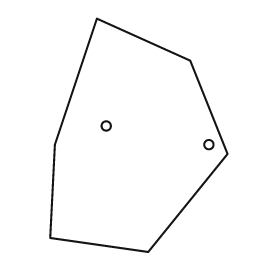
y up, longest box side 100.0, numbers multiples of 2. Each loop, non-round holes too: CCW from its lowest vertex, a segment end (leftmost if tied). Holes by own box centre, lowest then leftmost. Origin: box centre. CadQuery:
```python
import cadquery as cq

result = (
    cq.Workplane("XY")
    .moveTo(4.0, -50.0)
    .lineTo(38.0, -8.0)
    .lineTo(22.0, 32.0)
    .lineTo(-18.0, 50.0)
    .lineTo(-36.0, -4.0)
    .lineTo(-38.0, -44.0)
    .close()
    .moveTo(30.0, -4.0)
    .circle(2.0)
    .moveTo(-14.0, 4.0)
    .circle(2.0)
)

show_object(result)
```